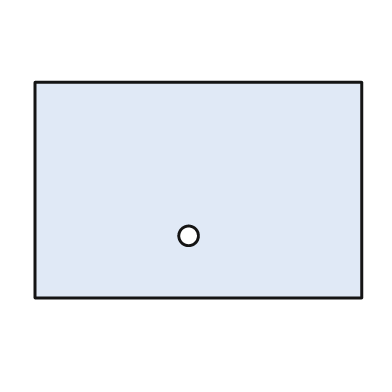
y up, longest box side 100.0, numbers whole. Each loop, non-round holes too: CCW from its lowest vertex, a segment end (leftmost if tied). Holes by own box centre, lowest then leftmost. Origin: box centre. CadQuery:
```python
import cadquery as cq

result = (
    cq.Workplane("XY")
    .moveTo(-50.0, -33.0)
    .lineTo(50.0, -33.0)
    .lineTo(50.0, 33.0)
    .lineTo(-50.0, 33.0)
    .close()
    .moveTo(-3.0, -14.0)
    .circle(3.0)
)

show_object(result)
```